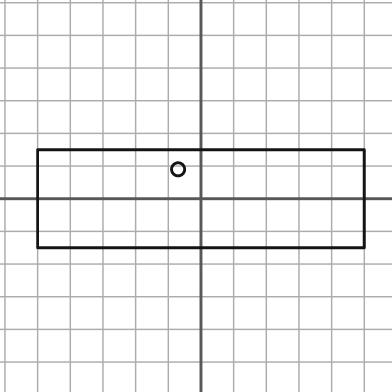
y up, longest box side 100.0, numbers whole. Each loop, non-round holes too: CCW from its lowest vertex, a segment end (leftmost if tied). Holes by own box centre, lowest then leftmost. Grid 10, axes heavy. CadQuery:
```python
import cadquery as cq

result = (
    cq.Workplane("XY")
    .moveTo(-50.0, -15.0)
    .lineTo(50.0, -15.0)
    .lineTo(50.0, 15.0)
    .lineTo(-50.0, 15.0)
    .close()
    .moveTo(-7.0, 9.0)
    .circle(2.0)
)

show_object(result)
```